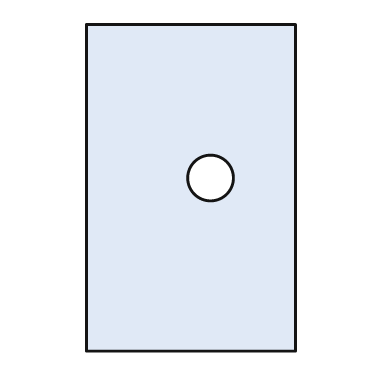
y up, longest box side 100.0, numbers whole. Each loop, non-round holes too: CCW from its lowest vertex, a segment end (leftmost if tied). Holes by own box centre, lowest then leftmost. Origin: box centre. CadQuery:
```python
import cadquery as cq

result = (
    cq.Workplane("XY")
    .moveTo(-32.0, -50.0)
    .lineTo(32.0, -50.0)
    .lineTo(32.0, 50.0)
    .lineTo(-32.0, 50.0)
    .close()
    .moveTo(6.0, 3.0)
    .circle(7.0)
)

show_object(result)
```